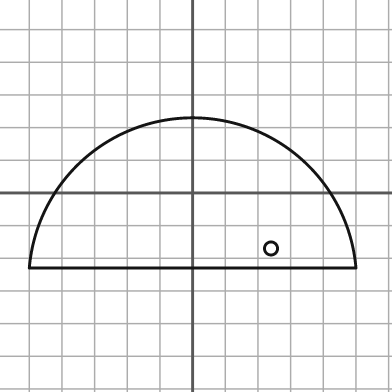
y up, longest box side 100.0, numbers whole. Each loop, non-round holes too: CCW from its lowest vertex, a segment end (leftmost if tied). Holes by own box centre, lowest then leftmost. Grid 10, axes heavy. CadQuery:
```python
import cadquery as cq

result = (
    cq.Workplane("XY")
    .moveTo(-50.0, -23.0)
    .lineTo(50.0, -23.0)
    .threePointArc((0.0, 23.0), (-50.0, -23.0))
    .close()
    .moveTo(24.0, -17.0)
    .circle(2.0)
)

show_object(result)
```